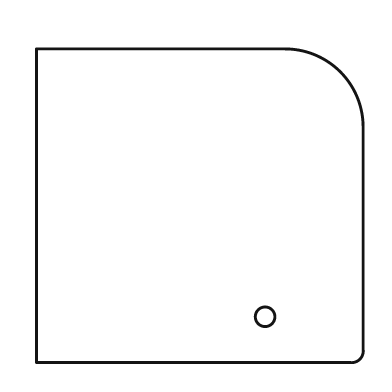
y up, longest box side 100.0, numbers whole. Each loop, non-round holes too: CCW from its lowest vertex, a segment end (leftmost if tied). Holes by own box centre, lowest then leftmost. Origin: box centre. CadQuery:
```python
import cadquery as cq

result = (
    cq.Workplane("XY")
    .moveTo(-50.0, -48.0)
    .lineTo(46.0, -48.0)
    .threePointArc((49.0, -47.0), (50.0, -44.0))
    .lineTo(50.0, 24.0)
    .threePointArc((43.0, 41.0), (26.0, 48.0))
    .lineTo(-50.0, 48.0)
    .close()
    .moveTo(20.0, -34.0)
    .circle(3.0)
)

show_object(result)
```